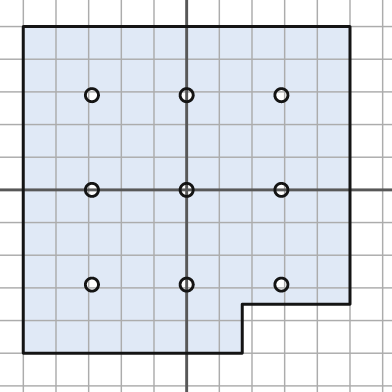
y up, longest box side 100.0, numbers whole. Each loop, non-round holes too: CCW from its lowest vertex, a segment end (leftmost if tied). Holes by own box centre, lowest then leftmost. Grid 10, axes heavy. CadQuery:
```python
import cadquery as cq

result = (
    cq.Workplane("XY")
    .moveTo(-50.0, -50.0)
    .lineTo(17.0, -50.0)
    .lineTo(17.0, -35.0)
    .lineTo(50.0, -35.0)
    .lineTo(50.0, 50.0)
    .lineTo(-50.0, 50.0)
    .close()
    .moveTo(-29.0, -29.0)
    .circle(2.0)
    .moveTo(0.0, -29.0)
    .circle(2.0)
    .moveTo(29.0, -29.0)
    .circle(2.0)
    .moveTo(-29.0, 0.0)
    .circle(2.0)
    .moveTo(0.0, 0.0)
    .circle(2.0)
    .moveTo(29.0, 0.0)
    .circle(2.0)
    .moveTo(-29.0, 29.0)
    .circle(2.0)
    .moveTo(0.0, 29.0)
    .circle(2.0)
    .moveTo(29.0, 29.0)
    .circle(2.0)
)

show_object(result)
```